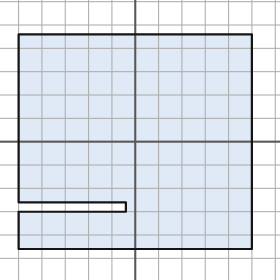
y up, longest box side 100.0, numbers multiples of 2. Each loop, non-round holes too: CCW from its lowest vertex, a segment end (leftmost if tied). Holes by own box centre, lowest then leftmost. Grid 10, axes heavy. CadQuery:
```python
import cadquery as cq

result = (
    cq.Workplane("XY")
    .moveTo(-50.0, -46.0)
    .lineTo(50.0, -46.0)
    .lineTo(50.0, 46.0)
    .lineTo(-50.0, 46.0)
    .lineTo(-50.0, -26.0)
    .lineTo(-4.0, -26.0)
    .lineTo(-4.0, -30.0)
    .lineTo(-50.0, -30.0)
    .close()
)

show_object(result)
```